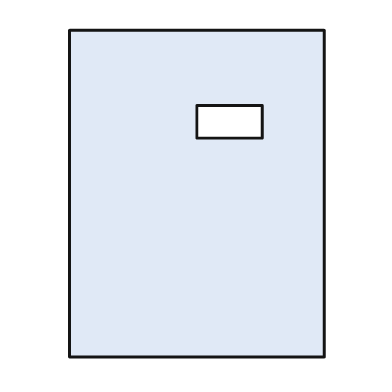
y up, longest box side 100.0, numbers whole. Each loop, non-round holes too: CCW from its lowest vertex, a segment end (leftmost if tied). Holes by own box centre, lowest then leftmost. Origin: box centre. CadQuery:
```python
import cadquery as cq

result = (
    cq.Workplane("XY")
    .moveTo(-39.0, -50.0)
    .lineTo(39.0, -50.0)
    .lineTo(39.0, 50.0)
    .lineTo(-39.0, 50.0)
    .close()
    .moveTo(0.0, 17.0)
    .lineTo(20.0, 17.0)
    .lineTo(20.0, 27.0)
    .lineTo(0.0, 27.0)
    .close()
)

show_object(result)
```